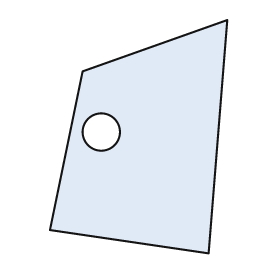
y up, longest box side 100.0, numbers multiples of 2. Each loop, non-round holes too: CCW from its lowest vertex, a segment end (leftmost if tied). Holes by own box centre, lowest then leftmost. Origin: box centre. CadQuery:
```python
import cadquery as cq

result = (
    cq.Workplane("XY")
    .moveTo(30.0, -50.0)
    .lineTo(38.0, 50.0)
    .lineTo(-24.0, 28.0)
    .lineTo(-38.0, -40.0)
    .close()
    .moveTo(-16.0, 2.0)
    .circle(8.0)
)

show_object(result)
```